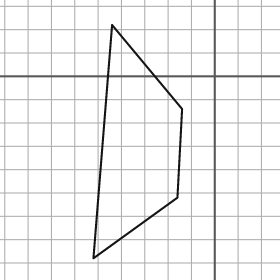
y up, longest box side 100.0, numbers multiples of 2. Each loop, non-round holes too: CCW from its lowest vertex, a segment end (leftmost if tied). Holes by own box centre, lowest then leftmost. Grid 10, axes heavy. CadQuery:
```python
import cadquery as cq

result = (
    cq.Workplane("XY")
    .moveTo(-52.0, -78.0)
    .lineTo(-16.0, -52.0)
    .lineTo(-14.0, -14.0)
    .lineTo(-44.0, 22.0)
    .close()
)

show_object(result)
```